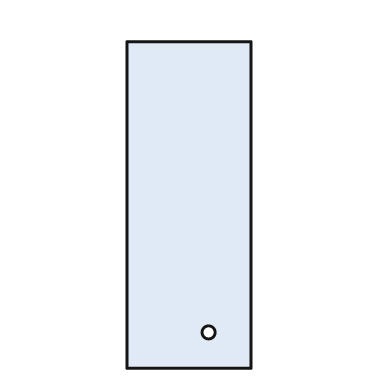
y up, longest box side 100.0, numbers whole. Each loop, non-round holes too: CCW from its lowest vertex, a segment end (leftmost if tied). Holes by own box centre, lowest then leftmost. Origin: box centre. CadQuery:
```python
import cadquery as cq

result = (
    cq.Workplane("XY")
    .moveTo(-19.0, -50.0)
    .lineTo(19.0, -50.0)
    .lineTo(19.0, 50.0)
    .lineTo(-19.0, 50.0)
    .close()
    .moveTo(6.0, -39.0)
    .circle(2.0)
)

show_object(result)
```